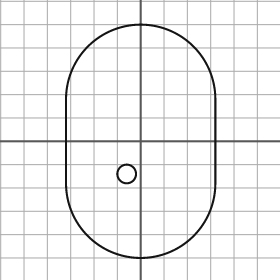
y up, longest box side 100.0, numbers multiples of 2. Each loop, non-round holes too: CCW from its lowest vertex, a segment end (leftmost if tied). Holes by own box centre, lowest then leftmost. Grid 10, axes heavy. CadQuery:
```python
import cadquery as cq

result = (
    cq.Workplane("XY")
    .moveTo(-32.0, -18.0)
    .threePointArc((0.0, -50.0), (32.0, -18.0))
    .lineTo(32.0, 18.0)
    .threePointArc((0.0, 50.0), (-32.0, 18.0))
    .close()
    .moveTo(-6.0, -14.0)
    .circle(4.0)
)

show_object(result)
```